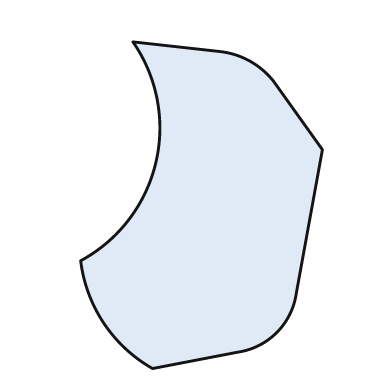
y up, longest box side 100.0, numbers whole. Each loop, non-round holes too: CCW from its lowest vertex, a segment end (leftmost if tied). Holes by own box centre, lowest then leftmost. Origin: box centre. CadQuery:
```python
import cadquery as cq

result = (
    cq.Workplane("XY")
    .moveTo(-15.0, -50.0)
    .lineTo(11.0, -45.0)
    .threePointArc((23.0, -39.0), (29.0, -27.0))
    .lineTo(37.0, 17.0)
    .lineTo(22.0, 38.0)
    .threePointArc((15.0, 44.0), (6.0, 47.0))
    .lineTo(-21.0, 50.0)
    .threePointArc((-14.0, 13.0), (-37.0, -17.0))
    .threePointArc((-30.0, -36.0), (-15.0, -50.0))
    .close()
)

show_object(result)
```